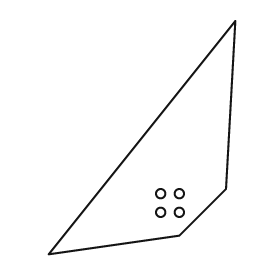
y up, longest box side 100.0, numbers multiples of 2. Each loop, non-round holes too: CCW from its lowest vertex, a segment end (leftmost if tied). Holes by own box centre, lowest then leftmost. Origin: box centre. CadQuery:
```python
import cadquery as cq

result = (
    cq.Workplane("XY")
    .moveTo(-40.0, -50.0)
    .lineTo(16.0, -42.0)
    .lineTo(36.0, -22.0)
    .lineTo(40.0, 50.0)
    .close()
    .moveTo(8.0, -32.0)
    .circle(2.0)
    .moveTo(16.0, -32.0)
    .circle(2.0)
    .moveTo(8.0, -24.0)
    .circle(2.0)
    .moveTo(16.0, -24.0)
    .circle(2.0)
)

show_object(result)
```